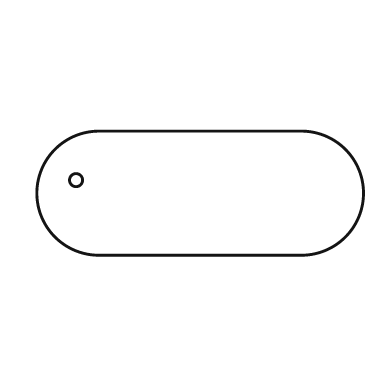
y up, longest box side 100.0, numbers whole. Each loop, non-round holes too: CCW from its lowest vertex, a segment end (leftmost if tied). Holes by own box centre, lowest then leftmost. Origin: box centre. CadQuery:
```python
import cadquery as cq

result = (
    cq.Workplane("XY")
    .moveTo(-31.0, -19.0)
    .lineTo(31.0, -19.0)
    .threePointArc((50.0, 0.0), (31.0, 19.0))
    .lineTo(-31.0, 19.0)
    .threePointArc((-50.0, 0.0), (-31.0, -19.0))
    .close()
    .moveTo(-38.0, 4.0)
    .circle(2.0)
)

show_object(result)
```